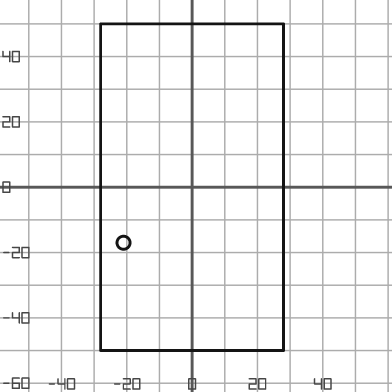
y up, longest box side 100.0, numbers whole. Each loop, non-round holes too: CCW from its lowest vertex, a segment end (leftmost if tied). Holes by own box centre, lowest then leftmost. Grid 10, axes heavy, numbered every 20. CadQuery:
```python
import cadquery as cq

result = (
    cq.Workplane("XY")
    .moveTo(-28.0, -50.0)
    .lineTo(28.0, -50.0)
    .lineTo(28.0, 50.0)
    .lineTo(-28.0, 50.0)
    .close()
    .moveTo(-21.0, -17.0)
    .circle(2.0)
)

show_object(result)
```